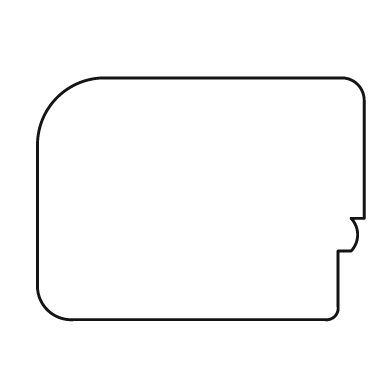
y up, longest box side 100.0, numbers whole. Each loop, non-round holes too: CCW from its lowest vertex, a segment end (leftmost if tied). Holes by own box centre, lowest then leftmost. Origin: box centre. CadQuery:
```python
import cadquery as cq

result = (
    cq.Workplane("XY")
    .moveTo(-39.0, -37.0)
    .lineTo(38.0, -37.0)
    .threePointArc((41.0, -36.0), (42.0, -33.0))
    .lineTo(42.0, -16.0)
    .lineTo(46.0, -16.0)
    .threePointArc((48.0, -11.0), (46.0, -6.0))
    .lineTo(50.0, -6.0)
    .lineTo(50.0, 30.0)
    .threePointArc((48.0, 35.0), (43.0, 37.0))
    .lineTo(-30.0, 37.0)
    .threePointArc((-44.0, 31.0), (-50.0, 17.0))
    .lineTo(-50.0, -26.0)
    .threePointArc((-47.0, -34.0), (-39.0, -37.0))
    .close()
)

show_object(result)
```